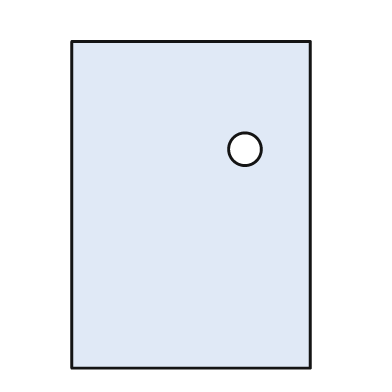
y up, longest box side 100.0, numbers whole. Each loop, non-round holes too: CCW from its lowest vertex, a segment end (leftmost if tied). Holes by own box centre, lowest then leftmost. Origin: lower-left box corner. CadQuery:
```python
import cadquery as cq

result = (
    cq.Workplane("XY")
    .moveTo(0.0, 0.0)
    .lineTo(73.0, 0.0)
    .lineTo(73.0, 100.0)
    .lineTo(0.0, 100.0)
    .close()
    .moveTo(53.0, 67.0)
    .circle(5.0)
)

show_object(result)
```